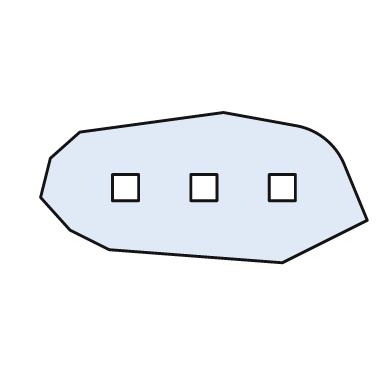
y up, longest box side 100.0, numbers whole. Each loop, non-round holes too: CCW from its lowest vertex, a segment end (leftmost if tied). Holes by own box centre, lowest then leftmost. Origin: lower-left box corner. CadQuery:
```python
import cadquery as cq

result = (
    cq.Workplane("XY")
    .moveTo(74.0, 0.0)
    .lineTo(100.0, 13.0)
    .lineTo(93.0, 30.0)
    .threePointArc((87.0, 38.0), (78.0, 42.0))
    .lineTo(56.0, 46.0)
    .lineTo(12.0, 40.0)
    .lineTo(3.0, 32.0)
    .lineTo(0.0, 20.0)
    .lineTo(9.0, 10.0)
    .lineTo(21.0, 4.0)
    .close()
    .moveTo(22.0, 19.0)
    .lineTo(30.0, 19.0)
    .lineTo(30.0, 27.0)
    .lineTo(22.0, 27.0)
    .close()
    .moveTo(46.0, 19.0)
    .lineTo(54.0, 19.0)
    .lineTo(54.0, 27.0)
    .lineTo(46.0, 27.0)
    .close()
    .moveTo(70.0, 19.0)
    .lineTo(78.0, 19.0)
    .lineTo(78.0, 27.0)
    .lineTo(70.0, 27.0)
    .close()
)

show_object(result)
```